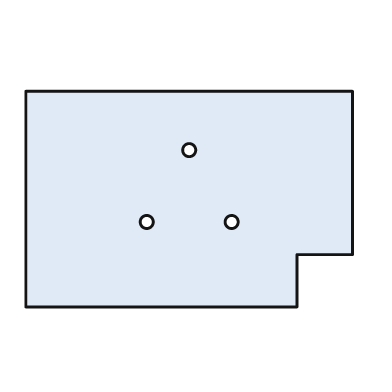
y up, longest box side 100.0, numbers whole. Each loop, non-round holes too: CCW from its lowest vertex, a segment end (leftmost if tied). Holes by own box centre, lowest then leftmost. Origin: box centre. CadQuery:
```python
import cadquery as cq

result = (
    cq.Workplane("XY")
    .moveTo(-50.0, -33.0)
    .lineTo(33.0, -33.0)
    .lineTo(33.0, -17.0)
    .lineTo(50.0, -17.0)
    .lineTo(50.0, 33.0)
    .lineTo(-50.0, 33.0)
    .close()
    .moveTo(-13.0, -7.0)
    .circle(2.0)
    .moveTo(13.0, -7.0)
    .circle(2.0)
    .moveTo(0.0, 15.0)
    .circle(2.0)
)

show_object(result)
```